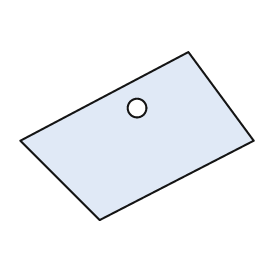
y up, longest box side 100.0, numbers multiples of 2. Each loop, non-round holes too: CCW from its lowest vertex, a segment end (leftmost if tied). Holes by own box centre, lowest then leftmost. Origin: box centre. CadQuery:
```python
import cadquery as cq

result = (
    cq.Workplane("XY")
    .moveTo(-16.0, -36.0)
    .lineTo(50.0, -2.0)
    .lineTo(22.0, 36.0)
    .lineTo(-50.0, -2.0)
    .close()
    .moveTo(0.0, 12.0)
    .circle(4.0)
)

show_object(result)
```